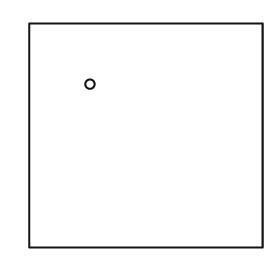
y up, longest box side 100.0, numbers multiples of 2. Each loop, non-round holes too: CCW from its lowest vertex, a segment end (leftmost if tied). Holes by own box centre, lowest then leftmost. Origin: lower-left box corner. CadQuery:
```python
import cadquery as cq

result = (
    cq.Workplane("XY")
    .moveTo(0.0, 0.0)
    .lineTo(100.0, 0.0)
    .lineTo(100.0, 96.0)
    .lineTo(0.0, 96.0)
    .close()
    .moveTo(26.0, 70.0)
    .circle(2.0)
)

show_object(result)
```